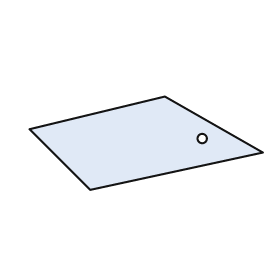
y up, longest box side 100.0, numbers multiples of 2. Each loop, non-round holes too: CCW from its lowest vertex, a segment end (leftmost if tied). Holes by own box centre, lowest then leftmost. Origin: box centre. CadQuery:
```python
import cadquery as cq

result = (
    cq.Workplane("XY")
    .moveTo(-24.0, -20.0)
    .lineTo(50.0, -4.0)
    .lineTo(8.0, 20.0)
    .lineTo(-50.0, 6.0)
    .close()
    .moveTo(24.0, 2.0)
    .circle(2.0)
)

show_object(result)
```